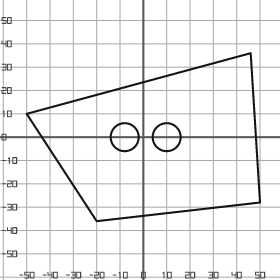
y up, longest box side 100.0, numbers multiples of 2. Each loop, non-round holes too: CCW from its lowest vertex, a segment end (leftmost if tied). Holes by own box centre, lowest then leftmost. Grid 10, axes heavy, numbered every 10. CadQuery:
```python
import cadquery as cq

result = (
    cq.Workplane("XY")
    .moveTo(-20.0, -36.0)
    .lineTo(50.0, -28.0)
    .lineTo(46.0, 36.0)
    .lineTo(-50.0, 10.0)
    .close()
    .moveTo(-8.0, 0.0)
    .circle(6.0)
    .moveTo(10.0, 0.0)
    .circle(6.0)
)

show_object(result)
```